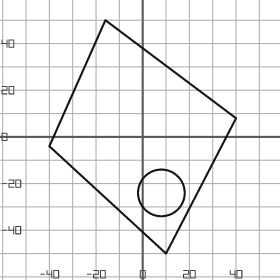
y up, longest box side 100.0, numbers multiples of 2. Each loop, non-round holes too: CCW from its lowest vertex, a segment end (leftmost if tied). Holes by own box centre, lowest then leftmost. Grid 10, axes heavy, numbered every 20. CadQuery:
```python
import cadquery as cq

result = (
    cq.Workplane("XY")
    .moveTo(10.0, -50.0)
    .lineTo(40.0, 8.0)
    .lineTo(-16.0, 50.0)
    .lineTo(-40.0, -4.0)
    .close()
    .moveTo(8.0, -24.0)
    .circle(10.0)
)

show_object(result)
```